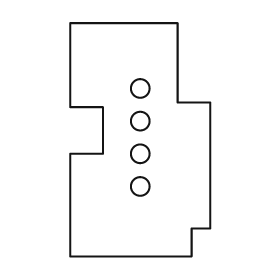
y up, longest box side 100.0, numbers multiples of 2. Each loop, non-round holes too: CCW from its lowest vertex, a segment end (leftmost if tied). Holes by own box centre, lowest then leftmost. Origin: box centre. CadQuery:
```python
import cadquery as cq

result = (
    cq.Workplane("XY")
    .moveTo(-30.0, -50.0)
    .lineTo(22.0, -50.0)
    .lineTo(22.0, -38.0)
    .lineTo(30.0, -38.0)
    .lineTo(30.0, 16.0)
    .lineTo(16.0, 16.0)
    .lineTo(16.0, 50.0)
    .lineTo(-30.0, 50.0)
    .lineTo(-30.0, 14.0)
    .lineTo(-16.0, 14.0)
    .lineTo(-16.0, -6.0)
    .lineTo(-30.0, -6.0)
    .close()
    .moveTo(0.0, -20.0)
    .circle(4.0)
    .moveTo(0.0, -6.0)
    .circle(4.0)
    .moveTo(0.0, 8.0)
    .circle(4.0)
    .moveTo(0.0, 22.0)
    .circle(4.0)
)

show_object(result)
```